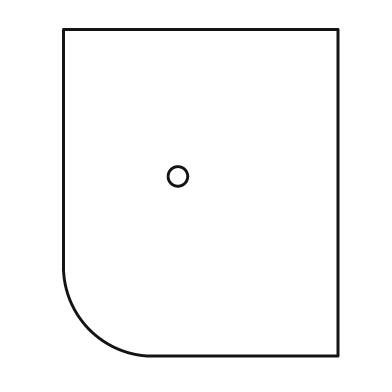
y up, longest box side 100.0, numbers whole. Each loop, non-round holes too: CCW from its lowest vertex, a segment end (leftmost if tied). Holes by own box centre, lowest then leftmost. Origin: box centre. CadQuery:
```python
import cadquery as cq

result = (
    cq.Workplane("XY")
    .moveTo(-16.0, -50.0)
    .lineTo(42.0, -50.0)
    .lineTo(42.0, 50.0)
    .lineTo(-42.0, 50.0)
    .lineTo(-42.0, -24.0)
    .threePointArc((-34.0, -42.0), (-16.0, -50.0))
    .close()
    .moveTo(-7.0, 5.0)
    .circle(3.0)
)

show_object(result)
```